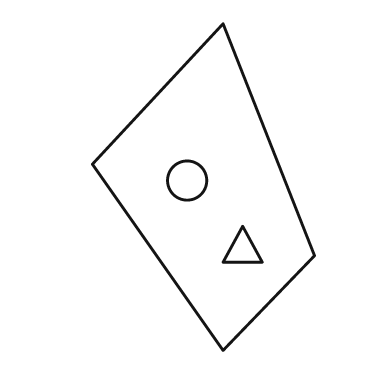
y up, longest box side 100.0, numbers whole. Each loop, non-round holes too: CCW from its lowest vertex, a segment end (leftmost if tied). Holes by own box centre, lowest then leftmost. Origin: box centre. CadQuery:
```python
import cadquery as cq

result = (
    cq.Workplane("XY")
    .moveTo(6.0, -50.0)
    .lineTo(34.0, -21.0)
    .lineTo(6.0, 50.0)
    .lineTo(-34.0, 7.0)
    .close()
    .moveTo(6.0, -23.0)
    .lineTo(18.0, -23.0)
    .lineTo(12.0, -12.0)
    .close()
    .moveTo(-5.0, 2.0)
    .circle(6.0)
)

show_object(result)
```